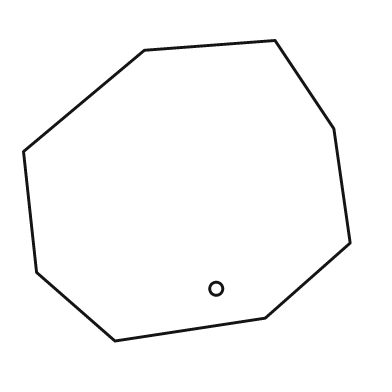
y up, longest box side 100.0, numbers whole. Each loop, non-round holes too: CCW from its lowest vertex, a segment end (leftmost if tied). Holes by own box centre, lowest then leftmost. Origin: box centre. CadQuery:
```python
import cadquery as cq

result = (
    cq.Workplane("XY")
    .moveTo(-22.0, -46.0)
    .lineTo(24.0, -39.0)
    .lineTo(50.0, -16.0)
    .lineTo(45.0, 19.0)
    .lineTo(27.0, 46.0)
    .lineTo(-13.0, 43.0)
    .lineTo(-50.0, 12.0)
    .lineTo(-46.0, -25.0)
    .close()
    .moveTo(9.0, -30.0)
    .circle(2.0)
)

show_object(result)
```